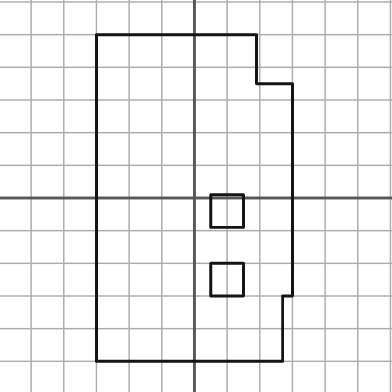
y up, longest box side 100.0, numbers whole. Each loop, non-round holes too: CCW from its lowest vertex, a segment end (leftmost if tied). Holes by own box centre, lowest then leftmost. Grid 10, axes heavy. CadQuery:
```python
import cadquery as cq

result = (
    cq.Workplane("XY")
    .moveTo(-30.0, -50.0)
    .lineTo(27.0, -50.0)
    .lineTo(27.0, -30.0)
    .lineTo(30.0, -30.0)
    .lineTo(30.0, 35.0)
    .lineTo(19.0, 35.0)
    .lineTo(19.0, 50.0)
    .lineTo(-30.0, 50.0)
    .close()
    .moveTo(5.0, -30.0)
    .lineTo(15.0, -30.0)
    .lineTo(15.0, -20.0)
    .lineTo(5.0, -20.0)
    .close()
    .moveTo(5.0, -9.0)
    .lineTo(15.0, -9.0)
    .lineTo(15.0, 1.0)
    .lineTo(5.0, 1.0)
    .close()
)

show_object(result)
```